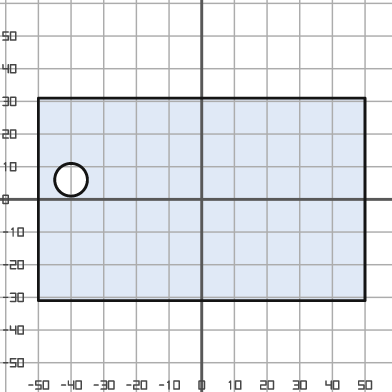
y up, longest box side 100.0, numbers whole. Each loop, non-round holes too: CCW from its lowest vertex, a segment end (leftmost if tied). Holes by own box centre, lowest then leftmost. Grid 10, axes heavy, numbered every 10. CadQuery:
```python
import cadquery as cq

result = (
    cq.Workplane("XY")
    .moveTo(-50.0, -31.0)
    .lineTo(50.0, -31.0)
    .lineTo(50.0, 31.0)
    .lineTo(-50.0, 31.0)
    .close()
    .moveTo(-40.0, 6.0)
    .circle(5.0)
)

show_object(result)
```